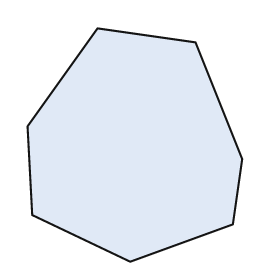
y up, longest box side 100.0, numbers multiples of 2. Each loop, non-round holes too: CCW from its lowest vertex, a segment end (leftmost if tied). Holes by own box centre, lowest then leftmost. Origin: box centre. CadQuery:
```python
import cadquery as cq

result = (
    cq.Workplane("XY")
    .moveTo(-2.0, -50.0)
    .lineTo(42.0, -34.0)
    .lineTo(46.0, -6.0)
    .lineTo(26.0, 44.0)
    .lineTo(-16.0, 50.0)
    .lineTo(-46.0, 8.0)
    .lineTo(-44.0, -30.0)
    .close()
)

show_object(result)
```